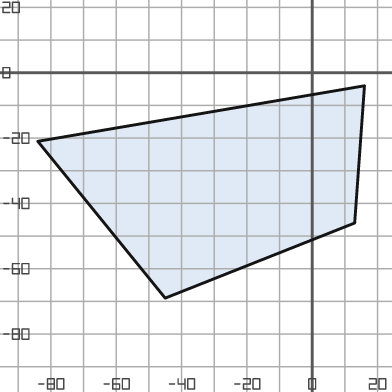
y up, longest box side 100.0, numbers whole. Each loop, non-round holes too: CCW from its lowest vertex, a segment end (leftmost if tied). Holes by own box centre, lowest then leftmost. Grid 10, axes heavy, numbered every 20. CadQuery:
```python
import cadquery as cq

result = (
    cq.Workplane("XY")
    .moveTo(-45.0, -69.0)
    .lineTo(13.0, -46.0)
    .lineTo(16.0, -4.0)
    .lineTo(-84.0, -21.0)
    .close()
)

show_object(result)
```